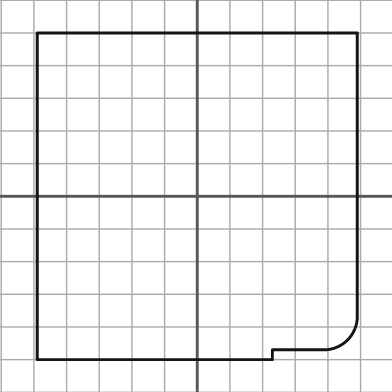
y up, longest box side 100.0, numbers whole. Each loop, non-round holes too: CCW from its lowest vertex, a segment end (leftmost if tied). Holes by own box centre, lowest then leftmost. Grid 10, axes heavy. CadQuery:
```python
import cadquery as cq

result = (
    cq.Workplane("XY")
    .moveTo(-49.0, -50.0)
    .lineTo(23.0, -50.0)
    .lineTo(23.0, -47.0)
    .lineTo(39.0, -47.0)
    .threePointArc((46.0, -44.0), (49.0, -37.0))
    .lineTo(49.0, 50.0)
    .lineTo(-49.0, 50.0)
    .close()
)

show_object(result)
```